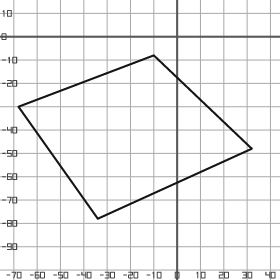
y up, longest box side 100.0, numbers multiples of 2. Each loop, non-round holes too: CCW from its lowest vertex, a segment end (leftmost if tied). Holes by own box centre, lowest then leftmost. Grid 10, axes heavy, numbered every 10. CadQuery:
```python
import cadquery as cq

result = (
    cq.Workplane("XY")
    .moveTo(-34.0, -78.0)
    .lineTo(32.0, -48.0)
    .lineTo(-10.0, -8.0)
    .lineTo(-68.0, -30.0)
    .close()
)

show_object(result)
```